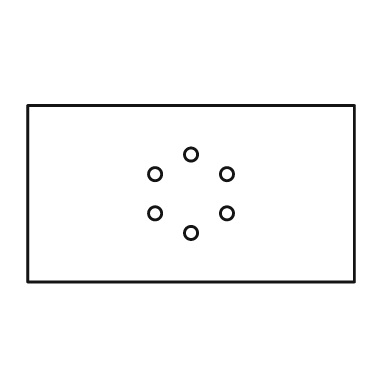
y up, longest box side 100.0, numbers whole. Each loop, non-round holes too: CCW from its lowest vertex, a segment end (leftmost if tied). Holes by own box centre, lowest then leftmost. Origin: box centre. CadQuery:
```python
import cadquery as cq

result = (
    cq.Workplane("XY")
    .moveTo(-50.0, -27.0)
    .lineTo(50.0, -27.0)
    .lineTo(50.0, 27.0)
    .lineTo(-50.0, 27.0)
    .close()
    .moveTo(0.0, -12.0)
    .circle(2.0)
    .moveTo(-11.0, -6.0)
    .circle(2.0)
    .moveTo(11.0, -6.0)
    .circle(2.0)
    .moveTo(-11.0, 6.0)
    .circle(2.0)
    .moveTo(11.0, 6.0)
    .circle(2.0)
    .moveTo(0.0, 12.0)
    .circle(2.0)
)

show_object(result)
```